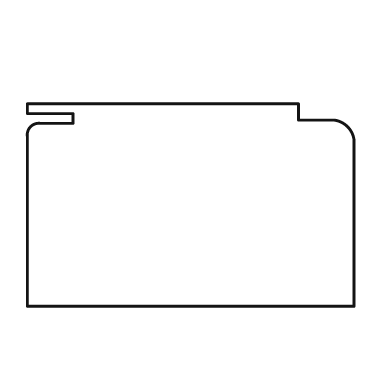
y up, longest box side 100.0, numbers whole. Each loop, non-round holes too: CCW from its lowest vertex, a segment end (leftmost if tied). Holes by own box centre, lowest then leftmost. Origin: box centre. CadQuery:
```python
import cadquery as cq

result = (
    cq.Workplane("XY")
    .moveTo(-50.0, -31.0)
    .lineTo(50.0, -31.0)
    .lineTo(50.0, 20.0)
    .threePointArc((48.0, 24.0), (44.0, 26.0))
    .lineTo(33.0, 26.0)
    .lineTo(33.0, 31.0)
    .lineTo(-50.0, 31.0)
    .lineTo(-50.0, 28.0)
    .lineTo(-36.0, 28.0)
    .lineTo(-36.0, 25.0)
    .lineTo(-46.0, 25.0)
    .threePointArc((-49.0, 24.0), (-50.0, 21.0))
    .close()
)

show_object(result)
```